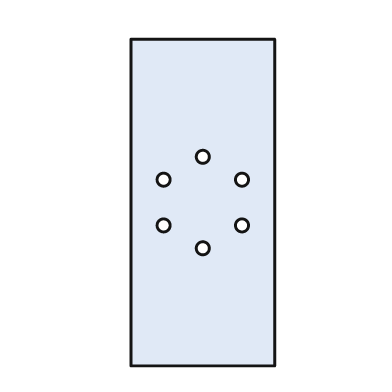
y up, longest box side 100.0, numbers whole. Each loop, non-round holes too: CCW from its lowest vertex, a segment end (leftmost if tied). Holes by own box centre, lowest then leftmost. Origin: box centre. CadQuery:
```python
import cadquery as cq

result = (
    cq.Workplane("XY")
    .moveTo(-22.0, -50.0)
    .lineTo(22.0, -50.0)
    .lineTo(22.0, 50.0)
    .lineTo(-22.0, 50.0)
    .close()
    .moveTo(0.0, -14.0)
    .circle(2.0)
    .moveTo(-12.0, -7.0)
    .circle(2.0)
    .moveTo(12.0, -7.0)
    .circle(2.0)
    .moveTo(-12.0, 7.0)
    .circle(2.0)
    .moveTo(12.0, 7.0)
    .circle(2.0)
    .moveTo(0.0, 14.0)
    .circle(2.0)
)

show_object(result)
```